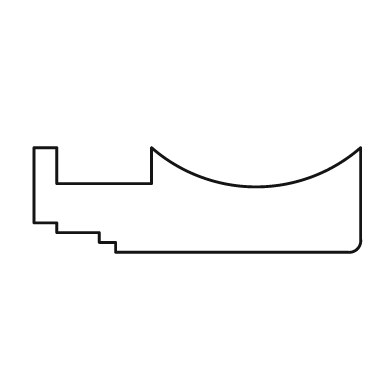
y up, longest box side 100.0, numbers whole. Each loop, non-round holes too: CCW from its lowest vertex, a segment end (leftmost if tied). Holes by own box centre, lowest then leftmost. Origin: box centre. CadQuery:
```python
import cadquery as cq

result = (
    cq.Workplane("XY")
    .moveTo(-25.0, -16.0)
    .lineTo(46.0, -16.0)
    .threePointArc((49.0, -15.0), (50.0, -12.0))
    .lineTo(50.0, 16.0)
    .threePointArc((18.0, 4.0), (-14.0, 16.0))
    .lineTo(-14.0, 5.0)
    .lineTo(-43.0, 5.0)
    .lineTo(-43.0, 16.0)
    .lineTo(-50.0, 16.0)
    .lineTo(-50.0, -7.0)
    .lineTo(-43.0, -7.0)
    .lineTo(-43.0, -10.0)
    .lineTo(-30.0, -10.0)
    .lineTo(-30.0, -13.0)
    .lineTo(-25.0, -13.0)
    .close()
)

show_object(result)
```